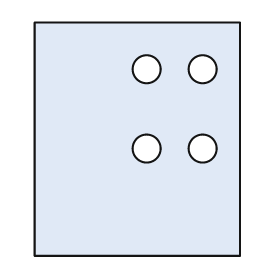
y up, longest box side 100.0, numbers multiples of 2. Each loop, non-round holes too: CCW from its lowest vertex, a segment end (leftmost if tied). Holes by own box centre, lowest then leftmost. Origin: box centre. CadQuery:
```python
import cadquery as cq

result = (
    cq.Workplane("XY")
    .moveTo(-44.0, -50.0)
    .lineTo(44.0, -50.0)
    .lineTo(44.0, 50.0)
    .lineTo(-44.0, 50.0)
    .close()
    .moveTo(4.0, -4.0)
    .circle(6.0)
    .moveTo(28.0, -4.0)
    .circle(6.0)
    .moveTo(4.0, 30.0)
    .circle(6.0)
    .moveTo(28.0, 30.0)
    .circle(6.0)
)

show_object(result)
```